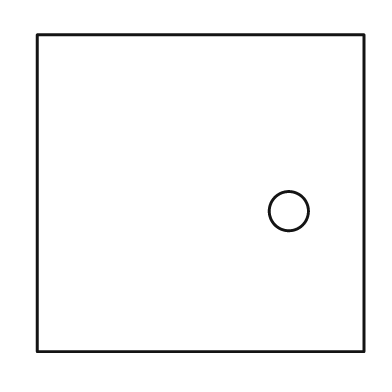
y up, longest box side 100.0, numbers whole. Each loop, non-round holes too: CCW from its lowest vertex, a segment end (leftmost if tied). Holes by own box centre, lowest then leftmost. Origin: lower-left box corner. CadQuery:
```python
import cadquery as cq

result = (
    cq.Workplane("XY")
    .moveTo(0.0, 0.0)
    .lineTo(100.0, 0.0)
    .lineTo(100.0, 97.0)
    .lineTo(0.0, 97.0)
    .close()
    .moveTo(77.0, 43.0)
    .circle(6.0)
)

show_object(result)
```